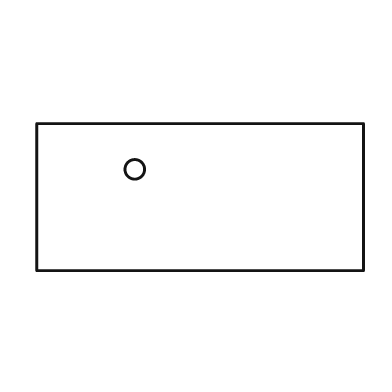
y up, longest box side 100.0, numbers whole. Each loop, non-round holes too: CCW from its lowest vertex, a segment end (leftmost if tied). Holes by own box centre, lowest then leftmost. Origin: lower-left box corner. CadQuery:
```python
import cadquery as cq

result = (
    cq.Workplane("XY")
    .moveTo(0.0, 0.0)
    .lineTo(100.0, 0.0)
    .lineTo(100.0, 45.0)
    .lineTo(0.0, 45.0)
    .close()
    .moveTo(30.0, 31.0)
    .circle(3.0)
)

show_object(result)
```